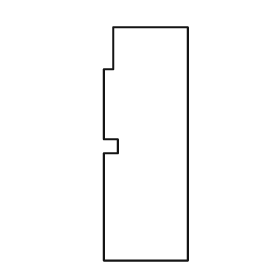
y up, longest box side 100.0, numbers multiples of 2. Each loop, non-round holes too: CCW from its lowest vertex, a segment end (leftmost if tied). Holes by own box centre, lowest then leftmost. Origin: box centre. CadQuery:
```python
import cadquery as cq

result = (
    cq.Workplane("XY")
    .moveTo(-18.0, -50.0)
    .lineTo(18.0, -50.0)
    .lineTo(18.0, 50.0)
    .lineTo(-14.0, 50.0)
    .lineTo(-14.0, 32.0)
    .lineTo(-18.0, 32.0)
    .lineTo(-18.0, 2.0)
    .lineTo(-12.0, 2.0)
    .lineTo(-12.0, -4.0)
    .lineTo(-18.0, -4.0)
    .close()
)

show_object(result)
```